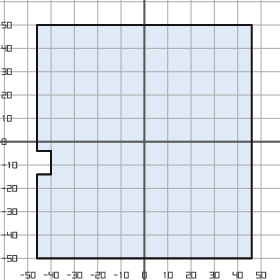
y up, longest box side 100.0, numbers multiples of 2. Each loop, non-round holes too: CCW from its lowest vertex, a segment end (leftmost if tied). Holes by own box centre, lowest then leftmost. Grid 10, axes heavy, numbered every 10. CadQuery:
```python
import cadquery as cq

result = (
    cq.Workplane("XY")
    .moveTo(-46.0, -50.0)
    .lineTo(46.0, -50.0)
    .lineTo(46.0, 50.0)
    .lineTo(-46.0, 50.0)
    .lineTo(-46.0, -4.0)
    .lineTo(-40.0, -4.0)
    .lineTo(-40.0, -14.0)
    .lineTo(-46.0, -14.0)
    .close()
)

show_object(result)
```